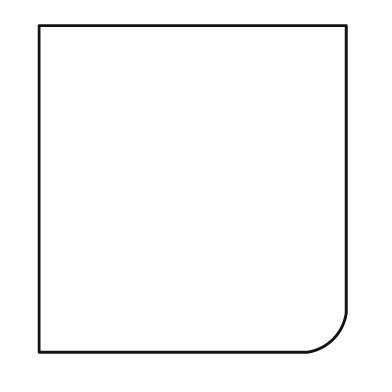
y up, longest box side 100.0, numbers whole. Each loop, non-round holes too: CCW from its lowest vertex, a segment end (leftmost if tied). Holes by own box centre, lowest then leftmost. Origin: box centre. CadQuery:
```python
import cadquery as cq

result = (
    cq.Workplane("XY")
    .moveTo(-47.0, -50.0)
    .lineTo(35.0, -50.0)
    .threePointArc((43.0, -46.0), (47.0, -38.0))
    .lineTo(47.0, 50.0)
    .lineTo(-47.0, 50.0)
    .close()
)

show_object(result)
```